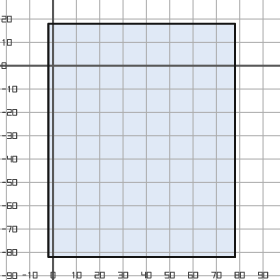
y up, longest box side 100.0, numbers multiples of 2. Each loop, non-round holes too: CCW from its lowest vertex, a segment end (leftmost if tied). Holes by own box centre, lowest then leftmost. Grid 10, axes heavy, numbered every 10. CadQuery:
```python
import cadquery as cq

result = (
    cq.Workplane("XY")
    .moveTo(-2.0, -82.0)
    .lineTo(78.0, -82.0)
    .lineTo(78.0, 18.0)
    .lineTo(-2.0, 18.0)
    .close()
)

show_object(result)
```